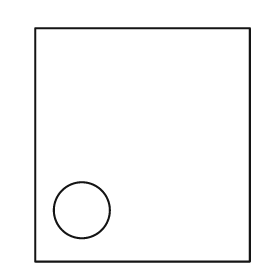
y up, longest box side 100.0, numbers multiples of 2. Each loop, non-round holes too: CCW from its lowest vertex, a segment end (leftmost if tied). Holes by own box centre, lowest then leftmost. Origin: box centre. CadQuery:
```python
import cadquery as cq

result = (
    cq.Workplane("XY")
    .moveTo(-46.0, -50.0)
    .lineTo(46.0, -50.0)
    .lineTo(46.0, 50.0)
    .lineTo(-46.0, 50.0)
    .close()
    .moveTo(-26.0, -28.0)
    .circle(12.0)
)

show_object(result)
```